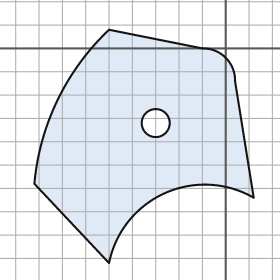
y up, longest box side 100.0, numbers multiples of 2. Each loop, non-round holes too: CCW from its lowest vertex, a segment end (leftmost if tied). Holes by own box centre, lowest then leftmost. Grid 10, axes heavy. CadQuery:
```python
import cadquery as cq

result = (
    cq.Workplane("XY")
    .moveTo(-50.0, -92.0)
    .threePointArc((-26.0, -62.0), (12.0, -64.0))
    .lineTo(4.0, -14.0)
    .threePointArc((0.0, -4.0), (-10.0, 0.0))
    .lineTo(-50.0, 8.0)
    .threePointArc((-72.0, -22.0), (-82.0, -58.0))
    .close()
    .moveTo(-30.0, -32.0)
    .circle(6.0)
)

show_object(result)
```